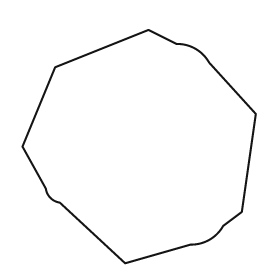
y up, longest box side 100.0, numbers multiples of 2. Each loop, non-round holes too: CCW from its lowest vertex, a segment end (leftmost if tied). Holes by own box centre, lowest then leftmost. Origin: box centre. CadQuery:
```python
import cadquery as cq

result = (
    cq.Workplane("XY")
    .moveTo(-6.0, -50.0)
    .lineTo(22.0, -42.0)
    .threePointArc((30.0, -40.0), (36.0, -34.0))
    .lineTo(44.0, -28.0)
    .lineTo(50.0, 14.0)
    .lineTo(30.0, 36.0)
    .threePointArc((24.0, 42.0), (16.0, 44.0))
    .lineTo(4.0, 50.0)
    .lineTo(-36.0, 34.0)
    .lineTo(-50.0, 0.0)
    .lineTo(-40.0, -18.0)
    .threePointArc((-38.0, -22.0), (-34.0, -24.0))
    .close()
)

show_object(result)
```